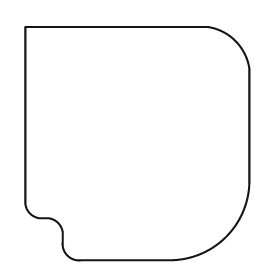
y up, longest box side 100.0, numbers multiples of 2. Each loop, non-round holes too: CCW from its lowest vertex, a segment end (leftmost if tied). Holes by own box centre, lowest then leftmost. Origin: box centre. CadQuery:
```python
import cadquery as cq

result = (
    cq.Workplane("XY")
    .moveTo(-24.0, -50.0)
    .lineTo(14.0, -50.0)
    .threePointArc((38.0, -40.0), (48.0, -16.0))
    .lineTo(48.0, 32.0)
    .threePointArc((42.0, 44.0), (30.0, 50.0))
    .lineTo(-48.0, 50.0)
    .lineTo(-48.0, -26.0)
    .threePointArc((-46.0, -30.0), (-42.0, -32.0))
    .lineTo(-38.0, -32.0)
    .threePointArc((-34.0, -34.0), (-32.0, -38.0))
    .lineTo(-32.0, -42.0)
    .threePointArc((-30.0, -48.0), (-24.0, -50.0))
    .close()
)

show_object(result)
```